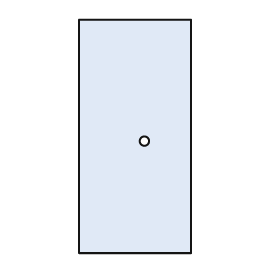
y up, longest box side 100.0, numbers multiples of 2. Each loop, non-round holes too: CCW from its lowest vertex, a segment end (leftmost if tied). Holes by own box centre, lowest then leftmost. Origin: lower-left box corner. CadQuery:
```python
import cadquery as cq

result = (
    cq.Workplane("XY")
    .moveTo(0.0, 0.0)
    .lineTo(48.0, 0.0)
    .lineTo(48.0, 100.0)
    .lineTo(0.0, 100.0)
    .close()
    .moveTo(28.0, 48.0)
    .circle(2.0)
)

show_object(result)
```